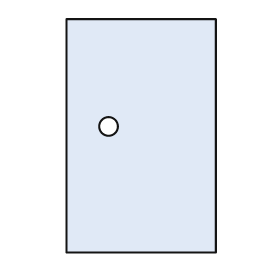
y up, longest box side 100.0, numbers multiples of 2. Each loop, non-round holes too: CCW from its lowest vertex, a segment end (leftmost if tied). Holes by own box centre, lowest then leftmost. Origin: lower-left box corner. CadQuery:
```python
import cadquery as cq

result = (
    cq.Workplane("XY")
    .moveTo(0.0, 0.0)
    .lineTo(64.0, 0.0)
    .lineTo(64.0, 100.0)
    .lineTo(0.0, 100.0)
    .close()
    .moveTo(18.0, 54.0)
    .circle(4.0)
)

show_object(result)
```